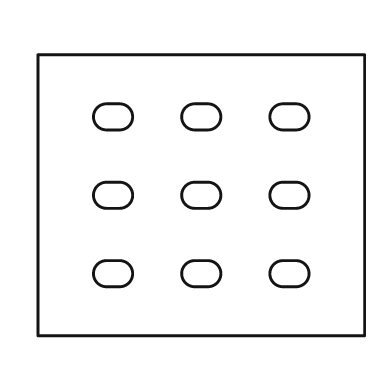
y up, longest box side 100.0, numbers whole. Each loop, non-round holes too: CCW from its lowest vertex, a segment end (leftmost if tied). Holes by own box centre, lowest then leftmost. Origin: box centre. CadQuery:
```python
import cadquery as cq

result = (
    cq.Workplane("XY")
    .moveTo(-50.0, -43.0)
    .lineTo(50.0, -43.0)
    .lineTo(50.0, 43.0)
    .lineTo(-50.0, 43.0)
    .close()
    .moveTo(-29.0, -28.0)
    .lineTo(-25.0, -28.0)
    .threePointArc((-21.0, -24.0), (-25.0, -20.0))
    .lineTo(-29.0, -20.0)
    .threePointArc((-33.0, -24.0), (-29.0, -28.0))
    .close()
    .moveTo(-2.0, -28.0)
    .lineTo(2.0, -28.0)
    .threePointArc((6.0, -24.0), (2.0, -20.0))
    .lineTo(-2.0, -20.0)
    .threePointArc((-6.0, -24.0), (-2.0, -28.0))
    .close()
    .moveTo(25.0, -28.0)
    .lineTo(29.0, -28.0)
    .threePointArc((33.0, -24.0), (29.0, -20.0))
    .lineTo(25.0, -20.0)
    .threePointArc((21.0, -24.0), (25.0, -28.0))
    .close()
    .moveTo(-29.0, -4.0)
    .lineTo(-25.0, -4.0)
    .threePointArc((-21.0, 0.0), (-25.0, 4.0))
    .lineTo(-29.0, 4.0)
    .threePointArc((-33.0, 0.0), (-29.0, -4.0))
    .close()
    .moveTo(-2.0, -4.0)
    .lineTo(2.0, -4.0)
    .threePointArc((6.0, 0.0), (2.0, 4.0))
    .lineTo(-2.0, 4.0)
    .threePointArc((-6.0, 0.0), (-2.0, -4.0))
    .close()
    .moveTo(25.0, -4.0)
    .lineTo(29.0, -4.0)
    .threePointArc((33.0, 0.0), (29.0, 4.0))
    .lineTo(25.0, 4.0)
    .threePointArc((21.0, 0.0), (25.0, -4.0))
    .close()
    .moveTo(-29.0, 20.0)
    .lineTo(-25.0, 20.0)
    .threePointArc((-21.0, 24.0), (-25.0, 28.0))
    .lineTo(-29.0, 28.0)
    .threePointArc((-33.0, 24.0), (-29.0, 20.0))
    .close()
    .moveTo(-2.0, 20.0)
    .lineTo(2.0, 20.0)
    .threePointArc((6.0, 24.0), (2.0, 28.0))
    .lineTo(-2.0, 28.0)
    .threePointArc((-6.0, 24.0), (-2.0, 20.0))
    .close()
    .moveTo(25.0, 20.0)
    .lineTo(29.0, 20.0)
    .threePointArc((33.0, 24.0), (29.0, 28.0))
    .lineTo(25.0, 28.0)
    .threePointArc((21.0, 24.0), (25.0, 20.0))
    .close()
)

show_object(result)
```